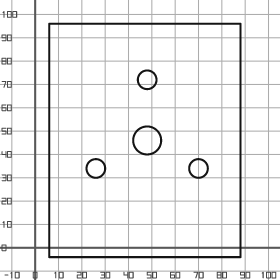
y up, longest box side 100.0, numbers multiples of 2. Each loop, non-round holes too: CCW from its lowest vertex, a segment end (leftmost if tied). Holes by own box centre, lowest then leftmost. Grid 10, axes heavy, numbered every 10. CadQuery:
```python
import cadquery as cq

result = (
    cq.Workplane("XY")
    .moveTo(6.0, -4.0)
    .lineTo(88.0, -4.0)
    .lineTo(88.0, 96.0)
    .lineTo(6.0, 96.0)
    .close()
    .moveTo(26.0, 34.0)
    .circle(4.0)
    .moveTo(70.0, 34.0)
    .circle(4.0)
    .moveTo(48.0, 46.0)
    .circle(6.0)
    .moveTo(48.0, 72.0)
    .circle(4.0)
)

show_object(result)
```